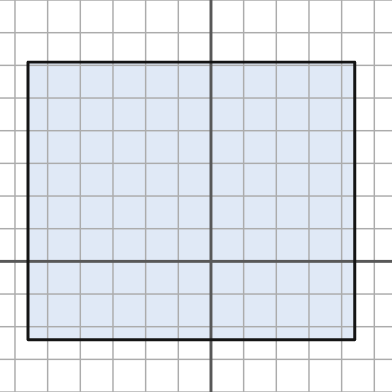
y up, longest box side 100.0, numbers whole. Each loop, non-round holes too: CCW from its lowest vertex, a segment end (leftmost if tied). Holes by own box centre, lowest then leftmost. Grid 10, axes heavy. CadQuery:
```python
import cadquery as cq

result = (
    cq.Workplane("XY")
    .moveTo(-56.0, -24.0)
    .lineTo(44.0, -24.0)
    .lineTo(44.0, 61.0)
    .lineTo(-56.0, 61.0)
    .close()
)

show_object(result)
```